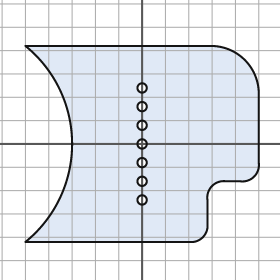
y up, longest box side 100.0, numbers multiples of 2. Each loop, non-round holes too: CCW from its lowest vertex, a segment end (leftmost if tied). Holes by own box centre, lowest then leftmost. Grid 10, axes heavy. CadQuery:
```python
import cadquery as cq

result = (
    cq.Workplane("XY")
    .moveTo(-50.0, -42.0)
    .lineTo(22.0, -42.0)
    .threePointArc((26.0, -40.0), (28.0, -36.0))
    .lineTo(28.0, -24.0)
    .threePointArc((30.0, -18.0), (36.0, -16.0))
    .lineTo(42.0, -16.0)
    .threePointArc((48.0, -14.0), (50.0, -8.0))
    .lineTo(50.0, 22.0)
    .threePointArc((44.0, 36.0), (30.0, 42.0))
    .lineTo(-50.0, 42.0)
    .threePointArc((-30.0, 0.0), (-50.0, -42.0))
    .close()
    .moveTo(0.0, -24.0)
    .circle(2.0)
    .moveTo(0.0, -16.0)
    .circle(2.0)
    .moveTo(0.0, -8.0)
    .circle(2.0)
    .moveTo(0.0, 0.0)
    .circle(2.0)
    .moveTo(0.0, 8.0)
    .circle(2.0)
    .moveTo(0.0, 16.0)
    .circle(2.0)
    .moveTo(0.0, 24.0)
    .circle(2.0)
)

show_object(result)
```